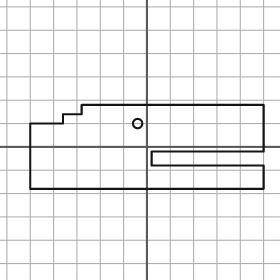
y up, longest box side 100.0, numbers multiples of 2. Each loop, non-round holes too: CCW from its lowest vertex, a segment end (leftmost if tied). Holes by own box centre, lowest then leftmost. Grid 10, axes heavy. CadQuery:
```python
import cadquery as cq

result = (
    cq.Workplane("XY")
    .moveTo(-50.0, -18.0)
    .lineTo(50.0, -18.0)
    .lineTo(50.0, -8.0)
    .lineTo(2.0, -8.0)
    .lineTo(2.0, -2.0)
    .lineTo(50.0, -2.0)
    .lineTo(50.0, 18.0)
    .lineTo(-28.0, 18.0)
    .lineTo(-28.0, 14.0)
    .lineTo(-36.0, 14.0)
    .lineTo(-36.0, 10.0)
    .lineTo(-50.0, 10.0)
    .close()
    .moveTo(-4.0, 10.0)
    .circle(2.0)
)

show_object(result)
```